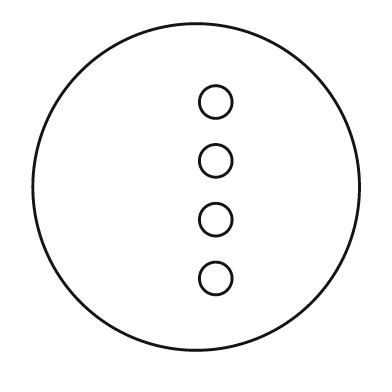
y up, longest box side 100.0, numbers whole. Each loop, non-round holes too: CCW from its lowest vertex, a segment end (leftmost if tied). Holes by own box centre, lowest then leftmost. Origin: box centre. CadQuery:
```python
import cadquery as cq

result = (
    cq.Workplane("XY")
    .moveTo(0.0, 0.0)
    .circle(50.0)
    .moveTo(6.0, -28.0)
    .circle(5.0)
    .moveTo(6.0, -10.0)
    .circle(5.0)
    .moveTo(6.0, 8.0)
    .circle(5.0)
    .moveTo(6.0, 26.0)
    .circle(5.0)
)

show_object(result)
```